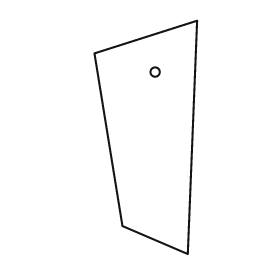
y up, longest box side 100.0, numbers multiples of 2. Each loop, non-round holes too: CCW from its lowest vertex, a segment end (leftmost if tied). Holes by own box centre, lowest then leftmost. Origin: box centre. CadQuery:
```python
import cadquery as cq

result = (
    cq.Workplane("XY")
    .moveTo(18.0, -50.0)
    .lineTo(22.0, 50.0)
    .lineTo(-22.0, 36.0)
    .lineTo(-10.0, -38.0)
    .close()
    .moveTo(4.0, 28.0)
    .circle(2.0)
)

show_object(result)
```